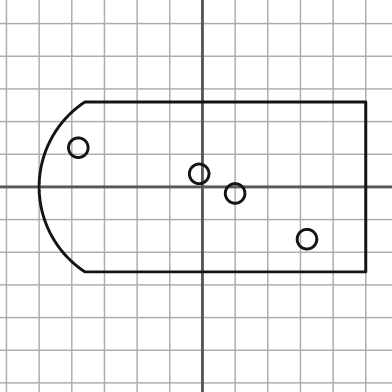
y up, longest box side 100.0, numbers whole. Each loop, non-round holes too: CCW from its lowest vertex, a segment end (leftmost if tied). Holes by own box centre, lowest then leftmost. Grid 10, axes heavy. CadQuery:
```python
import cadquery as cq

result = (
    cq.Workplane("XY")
    .moveTo(-36.0, -26.0)
    .lineTo(50.0, -26.0)
    .lineTo(50.0, 26.0)
    .lineTo(-36.0, 26.0)
    .threePointArc((-50.0, 0.0), (-36.0, -26.0))
    .close()
    .moveTo(32.0, -16.0)
    .circle(3.0)
    .moveTo(10.0, -2.0)
    .circle(3.0)
    .moveTo(-1.0, 4.0)
    .circle(3.0)
    .moveTo(-38.0, 12.0)
    .circle(3.0)
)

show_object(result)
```